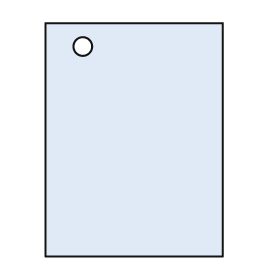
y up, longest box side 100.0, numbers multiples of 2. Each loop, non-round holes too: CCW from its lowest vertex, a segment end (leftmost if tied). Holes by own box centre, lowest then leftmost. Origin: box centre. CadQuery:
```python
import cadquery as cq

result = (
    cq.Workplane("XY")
    .moveTo(-38.0, -50.0)
    .lineTo(38.0, -50.0)
    .lineTo(38.0, 50.0)
    .lineTo(-38.0, 50.0)
    .close()
    .moveTo(-22.0, 40.0)
    .circle(4.0)
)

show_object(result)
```